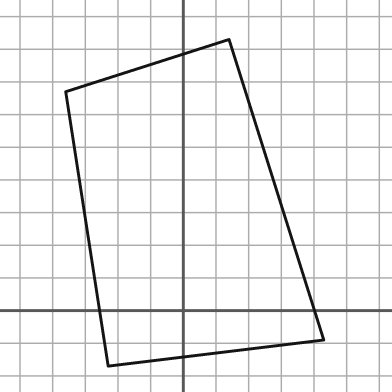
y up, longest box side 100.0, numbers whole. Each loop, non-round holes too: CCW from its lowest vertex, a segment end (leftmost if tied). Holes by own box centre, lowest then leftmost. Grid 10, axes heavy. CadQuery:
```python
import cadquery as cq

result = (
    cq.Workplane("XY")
    .moveTo(-23.0, -17.0)
    .lineTo(43.0, -9.0)
    .lineTo(14.0, 83.0)
    .lineTo(-36.0, 67.0)
    .close()
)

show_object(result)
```